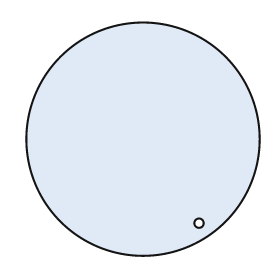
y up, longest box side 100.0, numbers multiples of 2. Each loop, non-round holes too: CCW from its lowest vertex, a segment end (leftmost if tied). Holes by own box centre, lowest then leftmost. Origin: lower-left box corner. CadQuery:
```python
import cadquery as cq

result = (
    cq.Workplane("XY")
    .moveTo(50.0, 50.0)
    .circle(50.0)
    .moveTo(74.0, 14.0)
    .circle(2.0)
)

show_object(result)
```